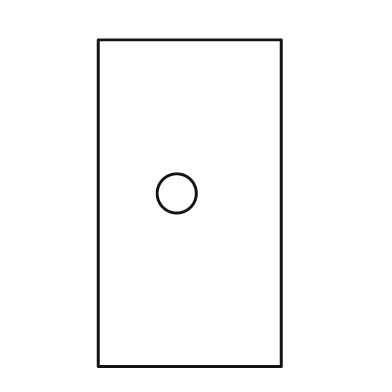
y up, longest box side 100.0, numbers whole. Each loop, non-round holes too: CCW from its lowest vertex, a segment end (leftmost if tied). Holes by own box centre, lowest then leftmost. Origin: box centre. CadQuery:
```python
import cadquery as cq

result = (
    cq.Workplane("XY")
    .moveTo(-28.0, -50.0)
    .lineTo(28.0, -50.0)
    .lineTo(28.0, 50.0)
    .lineTo(-28.0, 50.0)
    .close()
    .moveTo(-4.0, 3.0)
    .circle(6.0)
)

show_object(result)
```